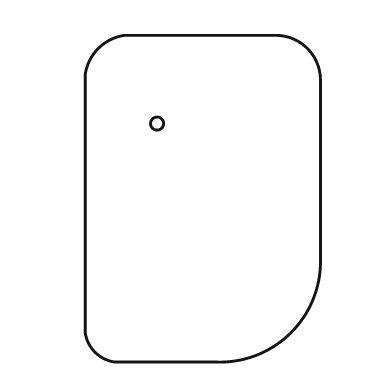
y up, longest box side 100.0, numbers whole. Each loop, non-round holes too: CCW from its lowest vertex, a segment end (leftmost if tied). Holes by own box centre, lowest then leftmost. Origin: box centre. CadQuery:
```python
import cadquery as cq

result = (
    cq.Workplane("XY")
    .moveTo(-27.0, -50.0)
    .lineTo(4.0, -50.0)
    .threePointArc((27.0, -41.0), (36.0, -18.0))
    .lineTo(36.0, 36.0)
    .threePointArc((32.0, 46.0), (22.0, 50.0))
    .lineTo(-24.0, 50.0)
    .threePointArc((-32.0, 46.0), (-36.0, 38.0))
    .lineTo(-36.0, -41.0)
    .threePointArc((-33.0, -47.0), (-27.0, -50.0))
    .close()
    .moveTo(-14.0, 23.0)
    .circle(2.0)
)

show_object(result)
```